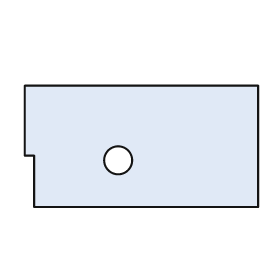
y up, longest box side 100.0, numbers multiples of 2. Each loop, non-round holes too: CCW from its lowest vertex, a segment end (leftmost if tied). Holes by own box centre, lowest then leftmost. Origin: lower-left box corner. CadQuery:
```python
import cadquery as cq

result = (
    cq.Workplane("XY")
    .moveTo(4.0, 0.0)
    .lineTo(100.0, 0.0)
    .lineTo(100.0, 52.0)
    .lineTo(0.0, 52.0)
    .lineTo(0.0, 22.0)
    .lineTo(4.0, 22.0)
    .close()
    .moveTo(40.0, 20.0)
    .circle(6.0)
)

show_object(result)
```